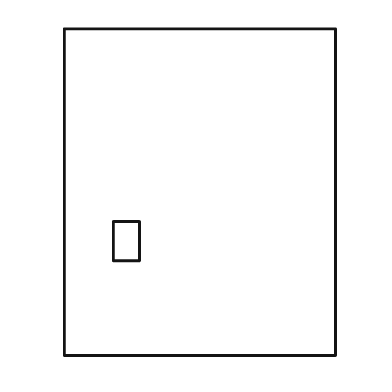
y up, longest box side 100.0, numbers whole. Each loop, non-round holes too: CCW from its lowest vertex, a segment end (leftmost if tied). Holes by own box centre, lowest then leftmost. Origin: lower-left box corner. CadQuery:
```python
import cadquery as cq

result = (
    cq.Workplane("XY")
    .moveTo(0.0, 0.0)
    .lineTo(83.0, 0.0)
    .lineTo(83.0, 100.0)
    .lineTo(0.0, 100.0)
    .close()
    .moveTo(15.0, 29.0)
    .lineTo(23.0, 29.0)
    .lineTo(23.0, 41.0)
    .lineTo(15.0, 41.0)
    .close()
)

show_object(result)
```